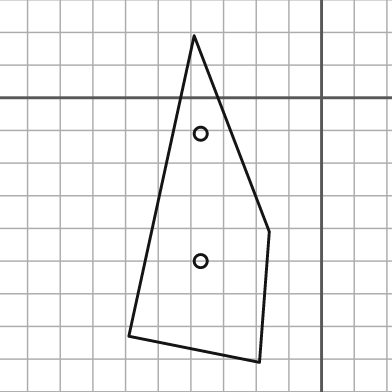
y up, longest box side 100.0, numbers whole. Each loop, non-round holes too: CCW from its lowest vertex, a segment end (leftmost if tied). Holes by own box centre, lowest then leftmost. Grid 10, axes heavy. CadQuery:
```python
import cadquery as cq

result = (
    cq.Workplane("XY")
    .moveTo(-19.0, -81.0)
    .lineTo(-16.0, -41.0)
    .lineTo(-39.0, 19.0)
    .lineTo(-59.0, -73.0)
    .close()
    .moveTo(-37.0, -50.0)
    .circle(2.0)
    .moveTo(-37.0, -11.0)
    .circle(2.0)
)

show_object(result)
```